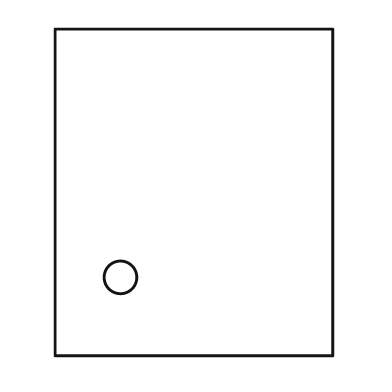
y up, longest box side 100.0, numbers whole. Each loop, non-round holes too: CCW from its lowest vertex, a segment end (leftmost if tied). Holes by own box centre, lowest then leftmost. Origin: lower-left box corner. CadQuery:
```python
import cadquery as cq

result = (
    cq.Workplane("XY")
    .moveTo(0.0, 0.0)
    .lineTo(85.0, 0.0)
    .lineTo(85.0, 100.0)
    .lineTo(0.0, 100.0)
    .close()
    .moveTo(20.0, 24.0)
    .circle(5.0)
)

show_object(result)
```